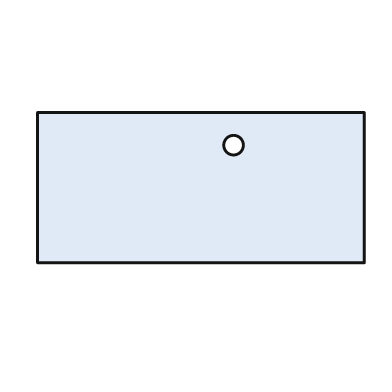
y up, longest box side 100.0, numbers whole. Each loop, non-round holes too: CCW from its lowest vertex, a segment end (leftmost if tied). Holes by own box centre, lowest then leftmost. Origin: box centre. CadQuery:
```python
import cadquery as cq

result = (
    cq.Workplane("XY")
    .moveTo(-50.0, -23.0)
    .lineTo(50.0, -23.0)
    .lineTo(50.0, 23.0)
    .lineTo(-50.0, 23.0)
    .close()
    .moveTo(10.0, 13.0)
    .circle(3.0)
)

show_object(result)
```